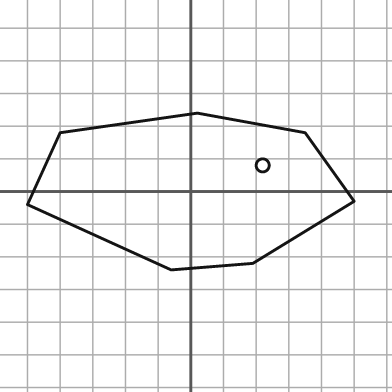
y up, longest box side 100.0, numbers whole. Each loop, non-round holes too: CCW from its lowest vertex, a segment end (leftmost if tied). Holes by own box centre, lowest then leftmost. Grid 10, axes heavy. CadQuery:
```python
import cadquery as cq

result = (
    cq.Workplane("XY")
    .moveTo(-6.0, -24.0)
    .lineTo(19.0, -22.0)
    .lineTo(50.0, -3.0)
    .lineTo(35.0, 18.0)
    .lineTo(2.0, 24.0)
    .lineTo(-40.0, 18.0)
    .lineTo(-50.0, -4.0)
    .close()
    .moveTo(22.0, 8.0)
    .circle(2.0)
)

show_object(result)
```